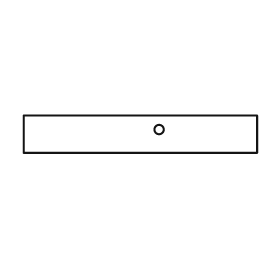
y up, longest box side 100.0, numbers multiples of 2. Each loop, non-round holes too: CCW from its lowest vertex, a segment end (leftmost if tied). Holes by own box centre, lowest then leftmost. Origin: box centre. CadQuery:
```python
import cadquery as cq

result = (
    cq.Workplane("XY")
    .moveTo(-50.0, -8.0)
    .lineTo(50.0, -8.0)
    .lineTo(50.0, 8.0)
    .lineTo(-50.0, 8.0)
    .close()
    .moveTo(8.0, 2.0)
    .circle(2.0)
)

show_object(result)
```